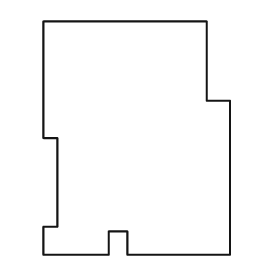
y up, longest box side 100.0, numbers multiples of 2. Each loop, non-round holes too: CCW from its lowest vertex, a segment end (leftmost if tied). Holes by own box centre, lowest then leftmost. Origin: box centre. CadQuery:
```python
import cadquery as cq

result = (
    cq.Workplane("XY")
    .moveTo(-40.0, -50.0)
    .lineTo(-12.0, -50.0)
    .lineTo(-12.0, -40.0)
    .lineTo(-4.0, -40.0)
    .lineTo(-4.0, -50.0)
    .lineTo(40.0, -50.0)
    .lineTo(40.0, 16.0)
    .lineTo(30.0, 16.0)
    .lineTo(30.0, 50.0)
    .lineTo(-40.0, 50.0)
    .lineTo(-40.0, 0.0)
    .lineTo(-34.0, 0.0)
    .lineTo(-34.0, -38.0)
    .lineTo(-40.0, -38.0)
    .close()
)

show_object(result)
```